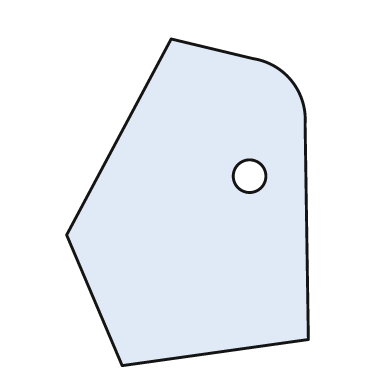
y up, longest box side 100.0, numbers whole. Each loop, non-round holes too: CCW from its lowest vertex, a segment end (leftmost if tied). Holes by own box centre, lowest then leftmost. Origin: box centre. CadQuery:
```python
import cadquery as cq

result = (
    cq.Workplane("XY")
    .moveTo(-20.0, -50.0)
    .lineTo(37.0, -42.0)
    .lineTo(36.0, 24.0)
    .threePointArc((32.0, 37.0), (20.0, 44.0))
    .lineTo(-5.0, 50.0)
    .lineTo(-37.0, -10.0)
    .close()
    .moveTo(19.0, 8.0)
    .circle(5.0)
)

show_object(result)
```